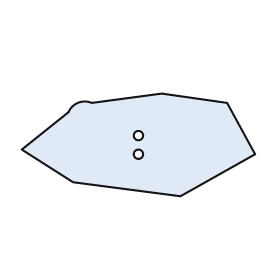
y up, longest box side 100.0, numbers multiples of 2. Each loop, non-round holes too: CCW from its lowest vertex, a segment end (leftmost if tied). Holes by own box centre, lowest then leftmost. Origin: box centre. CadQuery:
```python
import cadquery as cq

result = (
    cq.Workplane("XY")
    .moveTo(18.0, -22.0)
    .lineTo(50.0, -4.0)
    .lineTo(38.0, 18.0)
    .lineTo(10.0, 22.0)
    .lineTo(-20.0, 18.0)
    .threePointArc((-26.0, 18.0), (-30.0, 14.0))
    .lineTo(-50.0, -2.0)
    .lineTo(-28.0, -16.0)
    .close()
    .moveTo(0.0, -4.0)
    .circle(2.0)
    .moveTo(0.0, 4.0)
    .circle(2.0)
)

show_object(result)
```